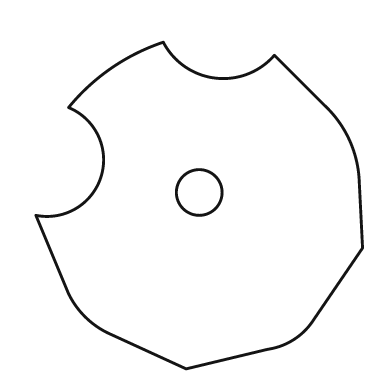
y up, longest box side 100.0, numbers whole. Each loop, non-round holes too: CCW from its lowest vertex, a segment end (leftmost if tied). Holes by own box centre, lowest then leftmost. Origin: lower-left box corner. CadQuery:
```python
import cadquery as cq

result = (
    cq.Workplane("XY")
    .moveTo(46.0, 0.0)
    .lineTo(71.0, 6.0)
    .threePointArc((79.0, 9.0), (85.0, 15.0))
    .lineTo(100.0, 37.0)
    .lineTo(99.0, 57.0)
    .threePointArc((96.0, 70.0), (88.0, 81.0))
    .lineTo(73.0, 96.0)
    .threePointArc((55.0, 89.0), (39.0, 100.0))
    .threePointArc((23.0, 92.0), (10.0, 80.0))
    .threePointArc((20.0, 59.0), (0.0, 47.0))
    .lineTo(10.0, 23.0)
    .threePointArc((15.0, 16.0), (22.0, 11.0))
    .close()
    .moveTo(50.0, 54.0)
    .circle(7.0)
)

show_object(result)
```